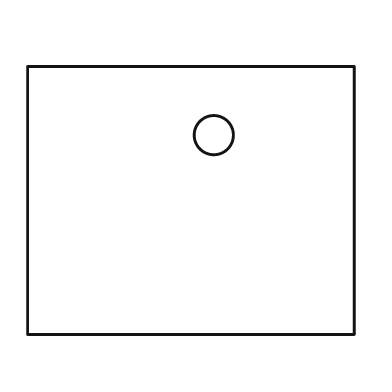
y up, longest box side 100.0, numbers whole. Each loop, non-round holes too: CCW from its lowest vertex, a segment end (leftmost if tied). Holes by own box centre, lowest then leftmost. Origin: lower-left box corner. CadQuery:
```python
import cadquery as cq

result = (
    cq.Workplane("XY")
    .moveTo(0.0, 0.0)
    .lineTo(100.0, 0.0)
    .lineTo(100.0, 82.0)
    .lineTo(0.0, 82.0)
    .close()
    .moveTo(57.0, 61.0)
    .circle(6.0)
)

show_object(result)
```